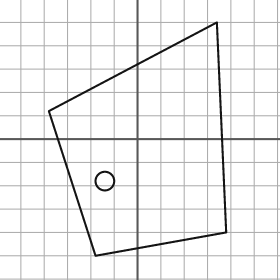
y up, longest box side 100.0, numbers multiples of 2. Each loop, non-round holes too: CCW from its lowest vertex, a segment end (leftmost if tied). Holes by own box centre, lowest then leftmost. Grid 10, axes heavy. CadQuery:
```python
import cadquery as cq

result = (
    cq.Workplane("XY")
    .moveTo(-18.0, -50.0)
    .lineTo(38.0, -40.0)
    .lineTo(34.0, 50.0)
    .lineTo(-38.0, 12.0)
    .close()
    .moveTo(-14.0, -18.0)
    .circle(4.0)
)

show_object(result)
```